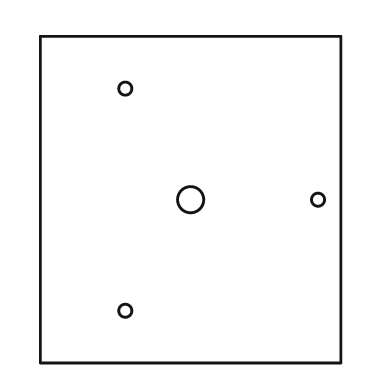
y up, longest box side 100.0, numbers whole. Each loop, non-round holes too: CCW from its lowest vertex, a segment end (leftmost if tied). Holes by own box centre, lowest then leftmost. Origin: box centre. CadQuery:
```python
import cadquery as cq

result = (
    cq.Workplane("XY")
    .moveTo(-46.0, -50.0)
    .lineTo(46.0, -50.0)
    .lineTo(46.0, 50.0)
    .lineTo(-46.0, 50.0)
    .close()
    .moveTo(-20.0, -34.0)
    .circle(2.0)
    .moveTo(0.0, 0.0)
    .circle(4.0)
    .moveTo(39.0, 0.0)
    .circle(2.0)
    .moveTo(-20.0, 34.0)
    .circle(2.0)
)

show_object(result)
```